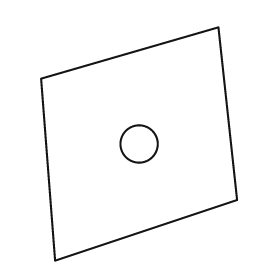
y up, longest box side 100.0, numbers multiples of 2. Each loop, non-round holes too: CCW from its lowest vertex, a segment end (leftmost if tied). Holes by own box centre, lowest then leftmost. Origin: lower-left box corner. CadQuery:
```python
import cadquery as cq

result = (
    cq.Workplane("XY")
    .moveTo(6.0, 0.0)
    .lineTo(84.0, 26.0)
    .lineTo(76.0, 100.0)
    .lineTo(0.0, 78.0)
    .close()
    .moveTo(42.0, 50.0)
    .circle(8.0)
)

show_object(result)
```